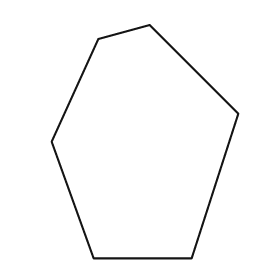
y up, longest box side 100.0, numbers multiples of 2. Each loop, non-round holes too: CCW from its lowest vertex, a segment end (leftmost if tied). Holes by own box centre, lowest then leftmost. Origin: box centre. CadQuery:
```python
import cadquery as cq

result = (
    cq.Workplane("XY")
    .moveTo(-22.0, -50.0)
    .lineTo(20.0, -50.0)
    .lineTo(40.0, 12.0)
    .lineTo(2.0, 50.0)
    .lineTo(-20.0, 44.0)
    .lineTo(-40.0, 0.0)
    .close()
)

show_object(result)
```